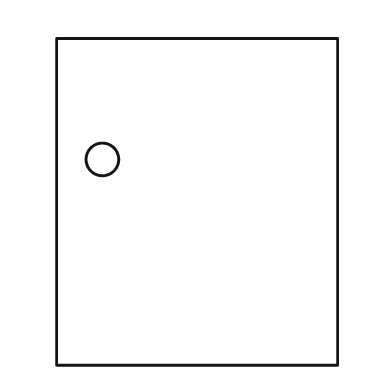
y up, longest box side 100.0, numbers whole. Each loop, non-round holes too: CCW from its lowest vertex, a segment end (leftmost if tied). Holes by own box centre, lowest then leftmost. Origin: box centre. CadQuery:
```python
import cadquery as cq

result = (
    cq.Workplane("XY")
    .moveTo(-43.0, -50.0)
    .lineTo(43.0, -50.0)
    .lineTo(43.0, 50.0)
    .lineTo(-43.0, 50.0)
    .close()
    .moveTo(-29.0, 13.0)
    .circle(5.0)
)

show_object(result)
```